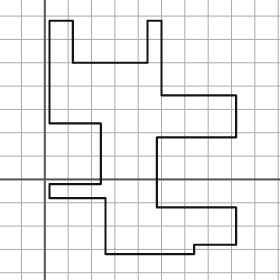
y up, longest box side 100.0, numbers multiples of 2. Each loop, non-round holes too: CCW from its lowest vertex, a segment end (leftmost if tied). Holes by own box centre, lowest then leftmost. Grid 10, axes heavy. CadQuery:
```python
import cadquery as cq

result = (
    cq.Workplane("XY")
    .moveTo(26.0, -32.0)
    .lineTo(64.0, -32.0)
    .lineTo(64.0, -28.0)
    .lineTo(82.0, -28.0)
    .lineTo(82.0, -12.0)
    .lineTo(48.0, -12.0)
    .lineTo(48.0, 18.0)
    .lineTo(82.0, 18.0)
    .lineTo(82.0, 36.0)
    .lineTo(50.0, 36.0)
    .lineTo(50.0, 68.0)
    .lineTo(44.0, 68.0)
    .lineTo(44.0, 50.0)
    .lineTo(12.0, 50.0)
    .lineTo(12.0, 68.0)
    .lineTo(2.0, 68.0)
    .lineTo(2.0, 24.0)
    .lineTo(24.0, 24.0)
    .lineTo(24.0, -2.0)
    .lineTo(2.0, -2.0)
    .lineTo(2.0, -8.0)
    .lineTo(26.0, -8.0)
    .close()
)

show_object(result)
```